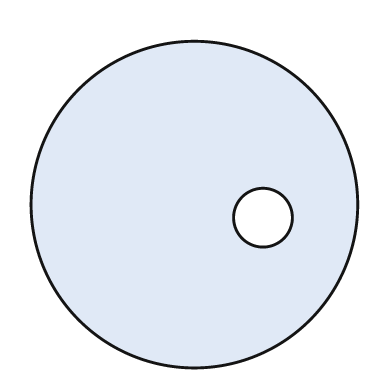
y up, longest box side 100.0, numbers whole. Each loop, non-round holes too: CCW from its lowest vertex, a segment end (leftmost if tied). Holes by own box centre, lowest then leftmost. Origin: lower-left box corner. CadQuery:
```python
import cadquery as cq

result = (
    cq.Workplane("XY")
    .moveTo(50.0, 50.0)
    .circle(50.0)
    .moveTo(71.0, 46.0)
    .circle(9.0)
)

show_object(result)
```